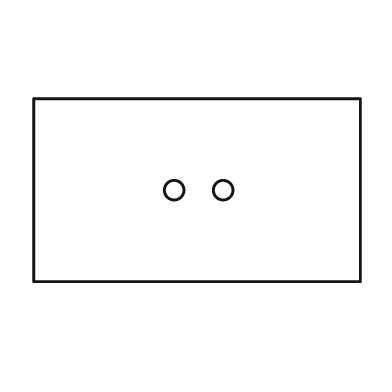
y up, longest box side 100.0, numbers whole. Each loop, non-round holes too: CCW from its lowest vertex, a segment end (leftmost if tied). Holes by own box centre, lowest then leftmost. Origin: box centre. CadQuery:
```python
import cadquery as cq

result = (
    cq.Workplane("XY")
    .moveTo(-50.0, -28.0)
    .lineTo(50.0, -28.0)
    .lineTo(50.0, 28.0)
    .lineTo(-50.0, 28.0)
    .close()
    .moveTo(-7.0, 0.0)
    .circle(3.0)
    .moveTo(8.0, 0.0)
    .circle(3.0)
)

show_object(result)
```